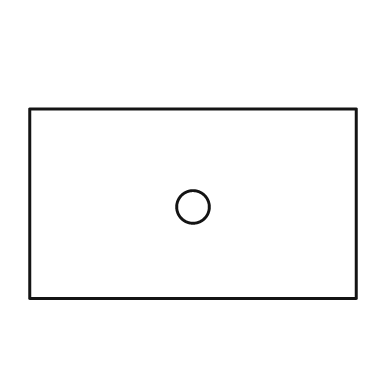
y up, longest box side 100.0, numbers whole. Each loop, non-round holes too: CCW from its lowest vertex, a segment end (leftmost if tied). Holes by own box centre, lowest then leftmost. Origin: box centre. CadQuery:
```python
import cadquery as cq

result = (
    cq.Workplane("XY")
    .moveTo(-50.0, -29.0)
    .lineTo(50.0, -29.0)
    .lineTo(50.0, 29.0)
    .lineTo(-50.0, 29.0)
    .close()
    .moveTo(0.0, -1.0)
    .circle(5.0)
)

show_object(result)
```